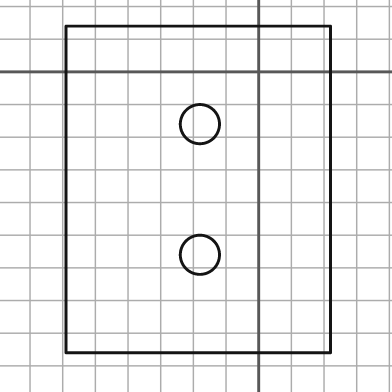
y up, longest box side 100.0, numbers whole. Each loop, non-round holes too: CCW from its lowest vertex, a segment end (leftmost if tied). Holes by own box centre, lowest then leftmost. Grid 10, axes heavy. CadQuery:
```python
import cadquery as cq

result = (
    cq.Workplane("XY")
    .moveTo(-59.0, -86.0)
    .lineTo(22.0, -86.0)
    .lineTo(22.0, 14.0)
    .lineTo(-59.0, 14.0)
    .close()
    .moveTo(-18.0, -56.0)
    .circle(6.0)
    .moveTo(-18.0, -16.0)
    .circle(6.0)
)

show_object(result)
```